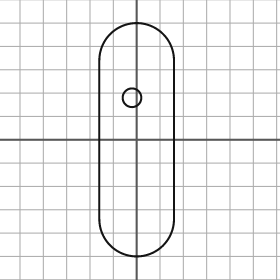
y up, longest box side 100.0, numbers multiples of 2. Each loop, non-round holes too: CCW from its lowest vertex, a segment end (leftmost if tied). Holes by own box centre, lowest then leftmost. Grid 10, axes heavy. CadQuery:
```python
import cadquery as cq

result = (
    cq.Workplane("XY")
    .moveTo(-16.0, -34.0)
    .threePointArc((0.0, -50.0), (16.0, -34.0))
    .lineTo(16.0, 34.0)
    .threePointArc((0.0, 50.0), (-16.0, 34.0))
    .close()
    .moveTo(-2.0, 18.0)
    .circle(4.0)
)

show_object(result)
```